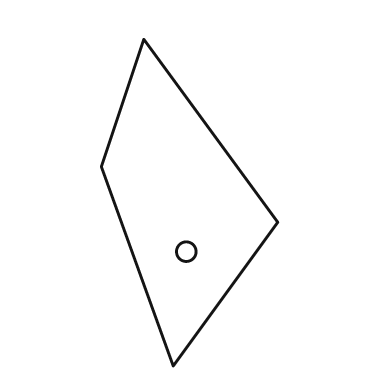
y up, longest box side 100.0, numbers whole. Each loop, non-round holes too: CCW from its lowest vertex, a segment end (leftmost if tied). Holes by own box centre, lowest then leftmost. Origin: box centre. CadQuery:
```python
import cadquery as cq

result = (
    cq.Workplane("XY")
    .moveTo(-5.0, -50.0)
    .lineTo(27.0, -6.0)
    .lineTo(-14.0, 50.0)
    .lineTo(-27.0, 11.0)
    .close()
    .moveTo(-1.0, -15.0)
    .circle(3.0)
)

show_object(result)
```